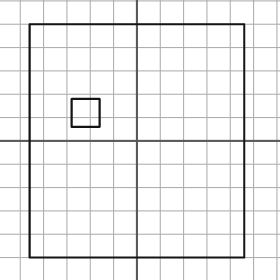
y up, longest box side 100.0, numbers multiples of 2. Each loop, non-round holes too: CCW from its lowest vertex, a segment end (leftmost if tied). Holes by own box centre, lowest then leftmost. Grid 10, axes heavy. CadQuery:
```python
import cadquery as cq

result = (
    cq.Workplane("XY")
    .moveTo(-46.0, -50.0)
    .lineTo(46.0, -50.0)
    .lineTo(46.0, 50.0)
    .lineTo(-46.0, 50.0)
    .close()
    .moveTo(-28.0, 6.0)
    .lineTo(-16.0, 6.0)
    .lineTo(-16.0, 18.0)
    .lineTo(-28.0, 18.0)
    .close()
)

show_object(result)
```